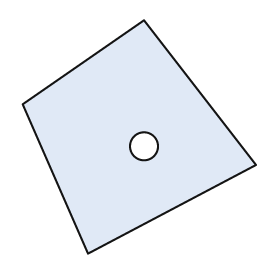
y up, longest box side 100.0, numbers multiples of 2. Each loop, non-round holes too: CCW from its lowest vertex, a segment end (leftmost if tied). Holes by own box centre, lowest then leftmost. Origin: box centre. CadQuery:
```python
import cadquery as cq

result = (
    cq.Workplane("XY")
    .moveTo(-22.0, -50.0)
    .lineTo(50.0, -12.0)
    .lineTo(2.0, 50.0)
    .lineTo(-50.0, 14.0)
    .close()
    .moveTo(2.0, -4.0)
    .circle(6.0)
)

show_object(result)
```